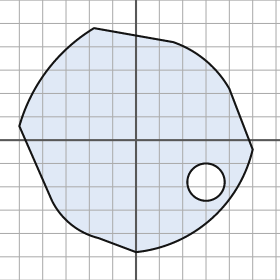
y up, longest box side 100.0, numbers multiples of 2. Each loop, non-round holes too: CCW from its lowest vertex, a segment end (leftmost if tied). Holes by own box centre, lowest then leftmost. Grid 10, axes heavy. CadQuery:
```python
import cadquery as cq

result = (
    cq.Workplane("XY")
    .moveTo(0.0, -48.0)
    .threePointArc((32.0, -34.0), (50.0, -4.0))
    .lineTo(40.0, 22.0)
    .threePointArc((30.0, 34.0), (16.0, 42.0))
    .lineTo(-18.0, 48.0)
    .threePointArc((-38.0, 30.0), (-50.0, 6.0))
    .lineTo(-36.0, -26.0)
    .threePointArc((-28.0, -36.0), (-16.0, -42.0))
    .close()
    .moveTo(30.0, -18.0)
    .circle(8.0)
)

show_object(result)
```